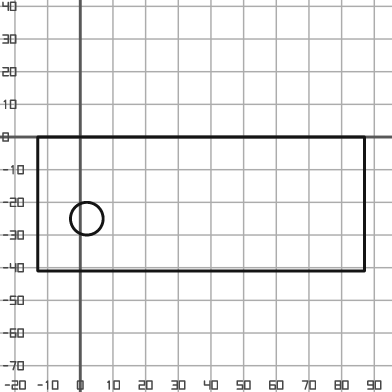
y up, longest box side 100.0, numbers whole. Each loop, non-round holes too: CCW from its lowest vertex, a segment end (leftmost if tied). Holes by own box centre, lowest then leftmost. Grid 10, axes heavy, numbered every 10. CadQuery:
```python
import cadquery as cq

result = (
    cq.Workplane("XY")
    .moveTo(-13.0, -41.0)
    .lineTo(87.0, -41.0)
    .lineTo(87.0, 0.0)
    .lineTo(-13.0, 0.0)
    .close()
    .moveTo(2.0, -25.0)
    .circle(5.0)
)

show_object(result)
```